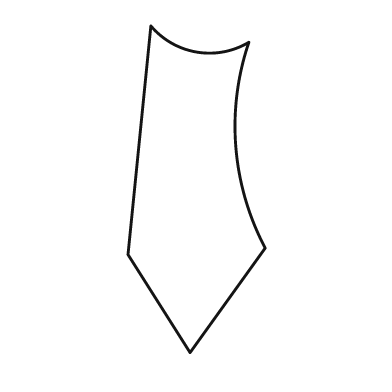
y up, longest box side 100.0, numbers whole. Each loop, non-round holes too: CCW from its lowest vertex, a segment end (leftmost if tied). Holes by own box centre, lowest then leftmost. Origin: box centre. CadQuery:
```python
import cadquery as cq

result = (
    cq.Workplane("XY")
    .moveTo(-2.0, -50.0)
    .lineTo(21.0, -18.0)
    .threePointArc((12.0, 13.0), (16.0, 45.0))
    .threePointArc((0.0, 42.0), (-14.0, 50.0))
    .lineTo(-21.0, -20.0)
    .close()
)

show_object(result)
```